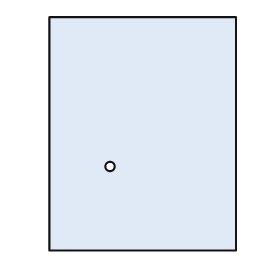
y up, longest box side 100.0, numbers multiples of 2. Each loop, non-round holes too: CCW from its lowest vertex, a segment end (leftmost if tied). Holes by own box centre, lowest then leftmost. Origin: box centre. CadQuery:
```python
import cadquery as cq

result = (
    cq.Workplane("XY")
    .moveTo(-40.0, -50.0)
    .lineTo(40.0, -50.0)
    .lineTo(40.0, 50.0)
    .lineTo(-40.0, 50.0)
    .close()
    .moveTo(-14.0, -14.0)
    .circle(2.0)
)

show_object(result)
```